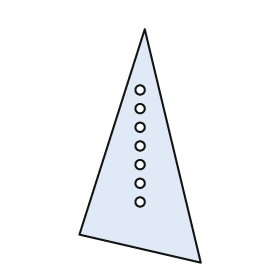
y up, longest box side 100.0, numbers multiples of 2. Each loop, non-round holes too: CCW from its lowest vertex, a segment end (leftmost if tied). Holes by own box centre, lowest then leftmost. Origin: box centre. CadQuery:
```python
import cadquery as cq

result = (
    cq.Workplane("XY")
    .moveTo(26.0, -50.0)
    .lineTo(2.0, 50.0)
    .lineTo(-26.0, -38.0)
    .close()
    .moveTo(0.0, -24.0)
    .circle(2.0)
    .moveTo(0.0, -16.0)
    .circle(2.0)
    .moveTo(0.0, -8.0)
    .circle(2.0)
    .moveTo(0.0, 0.0)
    .circle(2.0)
    .moveTo(0.0, 8.0)
    .circle(2.0)
    .moveTo(0.0, 16.0)
    .circle(2.0)
    .moveTo(0.0, 24.0)
    .circle(2.0)
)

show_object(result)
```